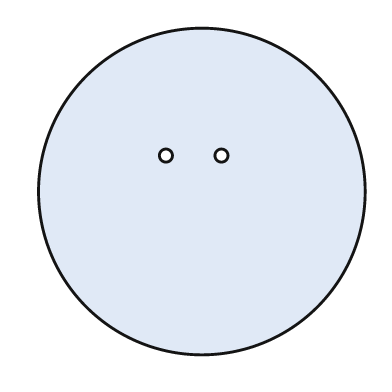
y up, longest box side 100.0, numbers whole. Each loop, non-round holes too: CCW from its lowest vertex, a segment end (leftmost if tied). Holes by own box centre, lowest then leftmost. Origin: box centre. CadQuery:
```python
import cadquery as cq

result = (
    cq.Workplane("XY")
    .moveTo(0.0, 0.0)
    .circle(50.0)
    .moveTo(-11.0, 11.0)
    .circle(2.0)
    .moveTo(6.0, 11.0)
    .circle(2.0)
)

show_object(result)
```